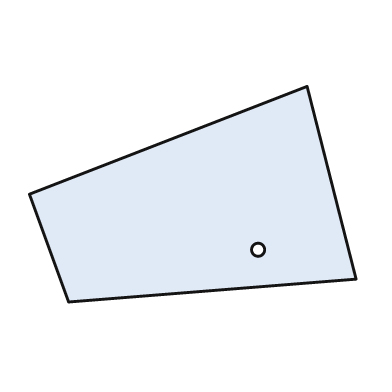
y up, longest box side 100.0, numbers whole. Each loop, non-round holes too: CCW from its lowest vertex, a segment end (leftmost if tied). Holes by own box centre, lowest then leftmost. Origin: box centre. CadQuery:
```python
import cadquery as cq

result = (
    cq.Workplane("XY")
    .moveTo(-38.0, -33.0)
    .lineTo(50.0, -26.0)
    .lineTo(35.0, 33.0)
    .lineTo(-50.0, 0.0)
    .close()
    .moveTo(20.0, -17.0)
    .circle(2.0)
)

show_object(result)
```